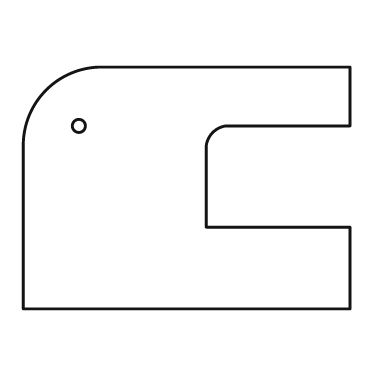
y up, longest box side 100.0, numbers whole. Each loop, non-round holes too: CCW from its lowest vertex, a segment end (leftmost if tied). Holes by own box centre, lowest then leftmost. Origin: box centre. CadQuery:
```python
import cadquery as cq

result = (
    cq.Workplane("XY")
    .moveTo(-50.0, -37.0)
    .lineTo(50.0, -37.0)
    .lineTo(50.0, -12.0)
    .lineTo(6.0, -12.0)
    .lineTo(6.0, 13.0)
    .threePointArc((8.0, 17.0), (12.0, 19.0))
    .lineTo(50.0, 19.0)
    .lineTo(50.0, 37.0)
    .lineTo(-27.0, 37.0)
    .threePointArc((-43.0, 30.0), (-50.0, 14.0))
    .close()
    .moveTo(-33.0, 19.0)
    .circle(2.0)
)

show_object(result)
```